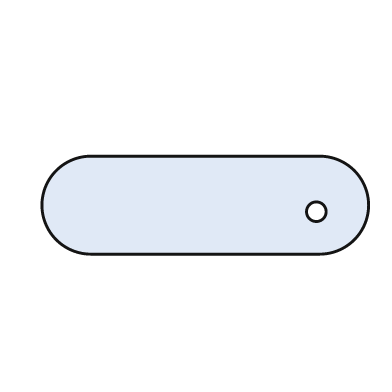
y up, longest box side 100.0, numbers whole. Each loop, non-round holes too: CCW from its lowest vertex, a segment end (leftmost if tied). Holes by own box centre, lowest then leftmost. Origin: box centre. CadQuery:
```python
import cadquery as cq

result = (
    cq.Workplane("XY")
    .moveTo(-35.0, -15.0)
    .lineTo(35.0, -15.0)
    .threePointArc((50.0, 0.0), (35.0, 15.0))
    .lineTo(-35.0, 15.0)
    .threePointArc((-50.0, 0.0), (-35.0, -15.0))
    .close()
    .moveTo(34.0, -2.0)
    .circle(3.0)
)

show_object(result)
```